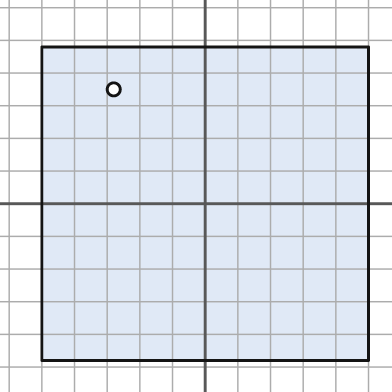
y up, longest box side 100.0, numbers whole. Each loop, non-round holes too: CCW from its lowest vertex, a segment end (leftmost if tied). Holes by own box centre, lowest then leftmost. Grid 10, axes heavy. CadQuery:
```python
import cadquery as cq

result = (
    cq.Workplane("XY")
    .moveTo(-50.0, -48.0)
    .lineTo(50.0, -48.0)
    .lineTo(50.0, 48.0)
    .lineTo(-50.0, 48.0)
    .close()
    .moveTo(-28.0, 35.0)
    .circle(2.0)
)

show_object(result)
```